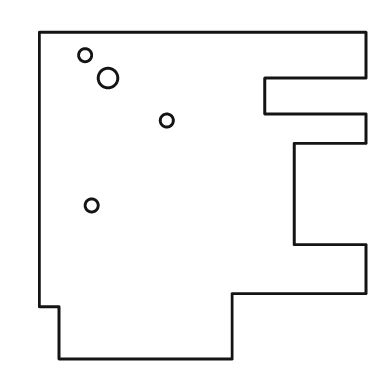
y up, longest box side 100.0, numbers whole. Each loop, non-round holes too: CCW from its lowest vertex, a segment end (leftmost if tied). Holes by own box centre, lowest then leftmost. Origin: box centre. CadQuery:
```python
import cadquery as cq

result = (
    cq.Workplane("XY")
    .moveTo(-44.0, -50.0)
    .lineTo(9.0, -50.0)
    .lineTo(9.0, -30.0)
    .lineTo(50.0, -30.0)
    .lineTo(50.0, -15.0)
    .lineTo(28.0, -15.0)
    .lineTo(28.0, 16.0)
    .lineTo(50.0, 16.0)
    .lineTo(50.0, 25.0)
    .lineTo(19.0, 25.0)
    .lineTo(19.0, 36.0)
    .lineTo(50.0, 36.0)
    .lineTo(50.0, 50.0)
    .lineTo(-50.0, 50.0)
    .lineTo(-50.0, -34.0)
    .lineTo(-44.0, -34.0)
    .close()
    .moveTo(-34.0, -3.0)
    .circle(2.0)
    .moveTo(-11.0, 23.0)
    .circle(2.0)
    .moveTo(-29.0, 36.0)
    .circle(3.0)
    .moveTo(-36.0, 43.0)
    .circle(2.0)
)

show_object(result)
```